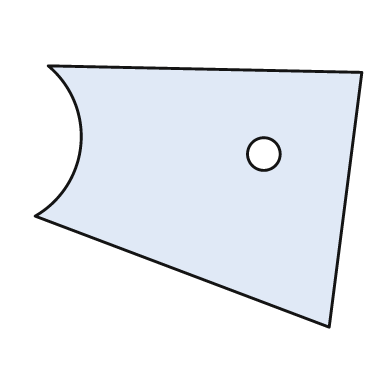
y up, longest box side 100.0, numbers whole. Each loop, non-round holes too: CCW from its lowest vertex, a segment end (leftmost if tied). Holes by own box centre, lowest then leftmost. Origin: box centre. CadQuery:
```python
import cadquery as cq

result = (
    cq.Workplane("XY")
    .moveTo(40.0, -40.0)
    .lineTo(50.0, 38.0)
    .lineTo(-46.0, 40.0)
    .threePointArc((-36.0, 16.0), (-50.0, -6.0))
    .close()
    .moveTo(20.0, 13.0)
    .circle(5.0)
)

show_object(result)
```